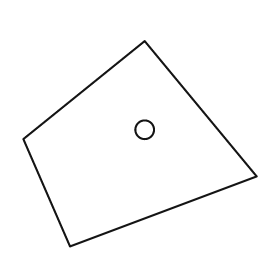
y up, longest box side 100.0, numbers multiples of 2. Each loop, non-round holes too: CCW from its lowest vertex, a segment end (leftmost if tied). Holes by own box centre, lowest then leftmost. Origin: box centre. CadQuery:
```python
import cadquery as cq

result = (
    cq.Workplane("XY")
    .moveTo(-30.0, -44.0)
    .lineTo(50.0, -14.0)
    .lineTo(2.0, 44.0)
    .lineTo(-50.0, 2.0)
    .close()
    .moveTo(2.0, 6.0)
    .circle(4.0)
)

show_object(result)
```